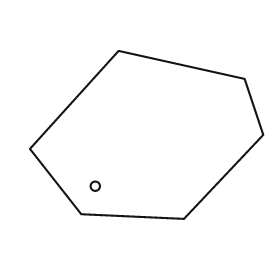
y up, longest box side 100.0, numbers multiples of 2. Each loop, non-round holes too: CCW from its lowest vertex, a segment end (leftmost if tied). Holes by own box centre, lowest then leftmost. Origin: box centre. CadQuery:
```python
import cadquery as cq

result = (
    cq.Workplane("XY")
    .moveTo(16.0, -36.0)
    .lineTo(50.0, 0.0)
    .lineTo(42.0, 24.0)
    .lineTo(-12.0, 36.0)
    .lineTo(-50.0, -6.0)
    .lineTo(-28.0, -34.0)
    .close()
    .moveTo(-22.0, -22.0)
    .circle(2.0)
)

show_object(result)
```